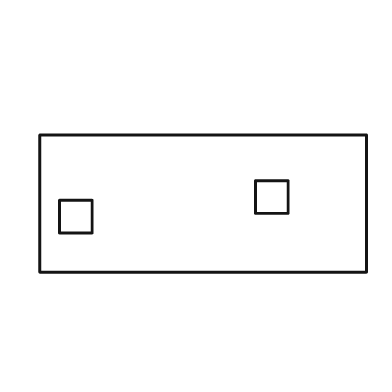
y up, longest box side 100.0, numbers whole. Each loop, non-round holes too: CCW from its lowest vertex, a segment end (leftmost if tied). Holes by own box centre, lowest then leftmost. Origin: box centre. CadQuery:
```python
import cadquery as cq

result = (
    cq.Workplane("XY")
    .moveTo(-50.0, -21.0)
    .lineTo(50.0, -21.0)
    .lineTo(50.0, 21.0)
    .lineTo(-50.0, 21.0)
    .close()
    .moveTo(-44.0, -9.0)
    .lineTo(-34.0, -9.0)
    .lineTo(-34.0, 1.0)
    .lineTo(-44.0, 1.0)
    .close()
    .moveTo(16.0, -3.0)
    .lineTo(26.0, -3.0)
    .lineTo(26.0, 7.0)
    .lineTo(16.0, 7.0)
    .close()
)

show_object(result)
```